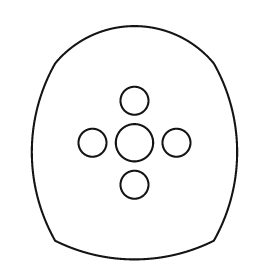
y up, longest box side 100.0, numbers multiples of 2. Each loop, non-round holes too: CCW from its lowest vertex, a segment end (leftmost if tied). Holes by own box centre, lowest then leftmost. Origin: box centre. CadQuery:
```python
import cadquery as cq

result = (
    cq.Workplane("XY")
    .moveTo(-34.0, -42.0)
    .threePointArc((0.0, -50.0), (34.0, -42.0))
    .threePointArc((44.0, -4.0), (34.0, 34.0))
    .threePointArc((0.0, 50.0), (-34.0, 34.0))
    .threePointArc((-44.0, -4.0), (-34.0, -42.0))
    .close()
    .moveTo(0.0, -18.0)
    .circle(6.0)
    .moveTo(-18.0, 0.0)
    .circle(6.0)
    .moveTo(0.0, 0.0)
    .circle(8.0)
    .moveTo(18.0, 0.0)
    .circle(6.0)
    .moveTo(0.0, 18.0)
    .circle(6.0)
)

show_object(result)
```